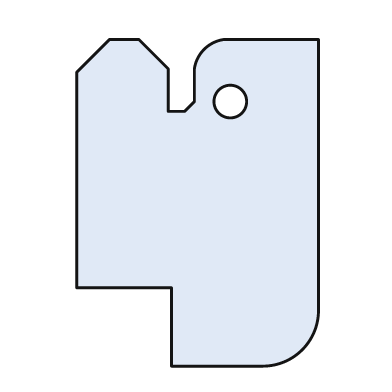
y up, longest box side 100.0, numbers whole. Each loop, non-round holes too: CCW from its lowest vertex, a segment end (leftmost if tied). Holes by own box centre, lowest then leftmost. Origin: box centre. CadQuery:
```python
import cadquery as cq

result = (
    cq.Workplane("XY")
    .moveTo(-8.0, -50.0)
    .lineTo(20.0, -50.0)
    .threePointArc((32.0, -45.0), (37.0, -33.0))
    .lineTo(37.0, 50.0)
    .lineTo(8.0, 50.0)
    .threePointArc((2.0, 47.0), (-1.0, 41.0))
    .lineTo(-1.0, 31.0)
    .lineTo(-4.0, 28.0)
    .lineTo(-9.0, 28.0)
    .lineTo(-9.0, 41.0)
    .lineTo(-18.0, 50.0)
    .lineTo(-27.0, 50.0)
    .lineTo(-37.0, 40.0)
    .lineTo(-37.0, -26.0)
    .lineTo(-8.0, -26.0)
    .close()
    .moveTo(10.0, 31.0)
    .circle(5.0)
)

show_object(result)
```